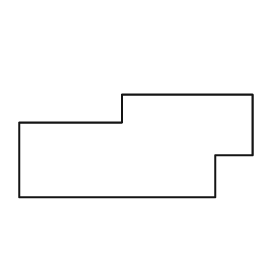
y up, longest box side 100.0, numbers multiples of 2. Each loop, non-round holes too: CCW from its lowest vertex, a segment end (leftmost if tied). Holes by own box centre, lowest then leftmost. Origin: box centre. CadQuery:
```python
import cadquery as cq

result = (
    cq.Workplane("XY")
    .moveTo(-50.0, -22.0)
    .lineTo(34.0, -22.0)
    .lineTo(34.0, -4.0)
    .lineTo(50.0, -4.0)
    .lineTo(50.0, 22.0)
    .lineTo(-6.0, 22.0)
    .lineTo(-6.0, 10.0)
    .lineTo(-50.0, 10.0)
    .close()
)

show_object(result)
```